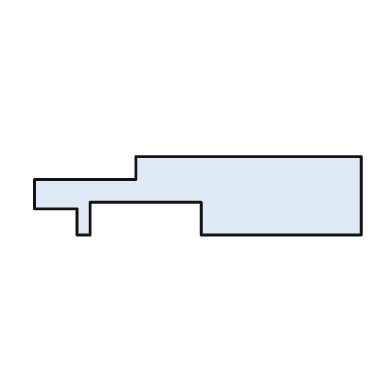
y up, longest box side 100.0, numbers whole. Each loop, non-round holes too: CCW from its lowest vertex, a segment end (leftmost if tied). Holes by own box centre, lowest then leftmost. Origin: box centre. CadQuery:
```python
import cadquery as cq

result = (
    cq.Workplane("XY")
    .moveTo(-37.0, -12.0)
    .lineTo(-33.0, -12.0)
    .lineTo(-33.0, -2.0)
    .lineTo(1.0, -2.0)
    .lineTo(1.0, -12.0)
    .lineTo(50.0, -12.0)
    .lineTo(50.0, 12.0)
    .lineTo(-19.0, 12.0)
    .lineTo(-19.0, 5.0)
    .lineTo(-50.0, 5.0)
    .lineTo(-50.0, -4.0)
    .lineTo(-37.0, -4.0)
    .close()
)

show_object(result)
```